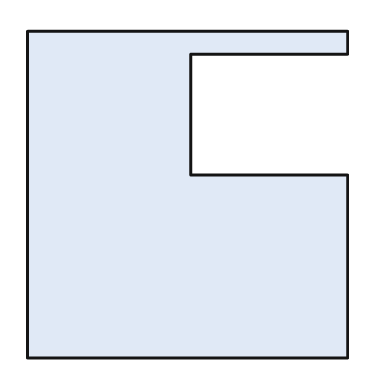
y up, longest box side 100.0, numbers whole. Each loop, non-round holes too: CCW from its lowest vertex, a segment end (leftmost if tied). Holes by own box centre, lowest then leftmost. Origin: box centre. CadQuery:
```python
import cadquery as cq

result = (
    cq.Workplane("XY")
    .moveTo(-49.0, -50.0)
    .lineTo(49.0, -50.0)
    .lineTo(49.0, 6.0)
    .lineTo(1.0, 6.0)
    .lineTo(1.0, 43.0)
    .lineTo(49.0, 43.0)
    .lineTo(49.0, 50.0)
    .lineTo(-49.0, 50.0)
    .close()
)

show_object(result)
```